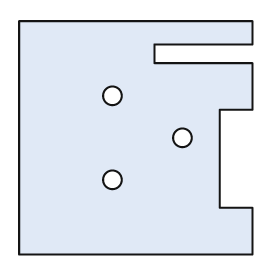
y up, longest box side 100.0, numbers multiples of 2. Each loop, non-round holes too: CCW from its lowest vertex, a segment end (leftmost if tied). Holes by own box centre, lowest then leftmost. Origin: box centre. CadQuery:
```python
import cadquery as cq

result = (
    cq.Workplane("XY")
    .moveTo(-50.0, -50.0)
    .lineTo(50.0, -50.0)
    .lineTo(50.0, -30.0)
    .lineTo(36.0, -30.0)
    .lineTo(36.0, 12.0)
    .lineTo(50.0, 12.0)
    .lineTo(50.0, 32.0)
    .lineTo(8.0, 32.0)
    .lineTo(8.0, 40.0)
    .lineTo(50.0, 40.0)
    .lineTo(50.0, 50.0)
    .lineTo(-50.0, 50.0)
    .close()
    .moveTo(-10.0, -18.0)
    .circle(4.0)
    .moveTo(20.0, 0.0)
    .circle(4.0)
    .moveTo(-10.0, 18.0)
    .circle(4.0)
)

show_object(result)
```